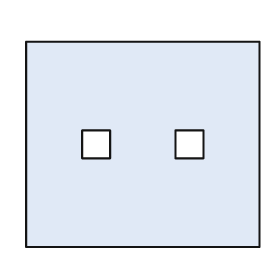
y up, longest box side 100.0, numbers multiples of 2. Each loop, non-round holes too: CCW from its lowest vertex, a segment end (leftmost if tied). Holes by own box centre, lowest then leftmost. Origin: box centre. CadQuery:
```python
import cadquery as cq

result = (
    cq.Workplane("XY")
    .moveTo(-50.0, -44.0)
    .lineTo(50.0, -44.0)
    .lineTo(50.0, 44.0)
    .lineTo(-50.0, 44.0)
    .close()
    .moveTo(-26.0, -6.0)
    .lineTo(-14.0, -6.0)
    .lineTo(-14.0, 6.0)
    .lineTo(-26.0, 6.0)
    .close()
    .moveTo(14.0, -6.0)
    .lineTo(26.0, -6.0)
    .lineTo(26.0, 6.0)
    .lineTo(14.0, 6.0)
    .close()
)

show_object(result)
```